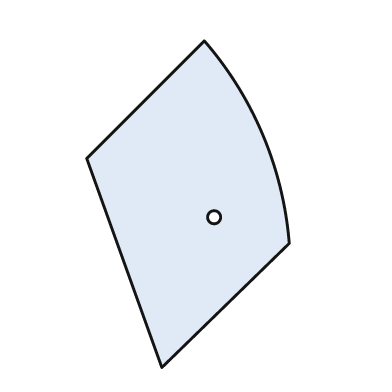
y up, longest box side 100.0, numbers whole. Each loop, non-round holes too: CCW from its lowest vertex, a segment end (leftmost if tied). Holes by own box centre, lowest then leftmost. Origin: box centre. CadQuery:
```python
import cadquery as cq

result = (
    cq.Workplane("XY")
    .moveTo(-8.0, -50.0)
    .lineTo(31.0, -12.0)
    .threePointArc((23.0, 21.0), (5.0, 50.0))
    .lineTo(-31.0, 14.0)
    .close()
    .moveTo(8.0, -4.0)
    .circle(2.0)
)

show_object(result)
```